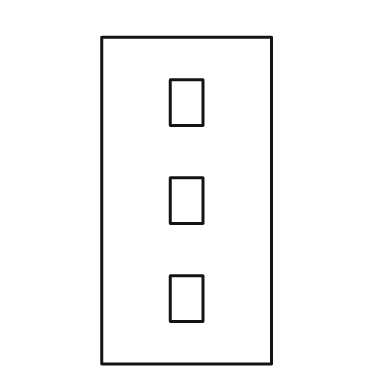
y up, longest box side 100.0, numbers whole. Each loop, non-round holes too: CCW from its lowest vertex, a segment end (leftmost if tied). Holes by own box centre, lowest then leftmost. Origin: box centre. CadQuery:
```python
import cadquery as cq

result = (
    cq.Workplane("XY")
    .moveTo(-26.0, -50.0)
    .lineTo(26.0, -50.0)
    .lineTo(26.0, 50.0)
    .lineTo(-26.0, 50.0)
    .close()
    .moveTo(-5.0, -37.0)
    .lineTo(5.0, -37.0)
    .lineTo(5.0, -23.0)
    .lineTo(-5.0, -23.0)
    .close()
    .moveTo(-5.0, -7.0)
    .lineTo(5.0, -7.0)
    .lineTo(5.0, 7.0)
    .lineTo(-5.0, 7.0)
    .close()
    .moveTo(-5.0, 23.0)
    .lineTo(5.0, 23.0)
    .lineTo(5.0, 37.0)
    .lineTo(-5.0, 37.0)
    .close()
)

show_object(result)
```